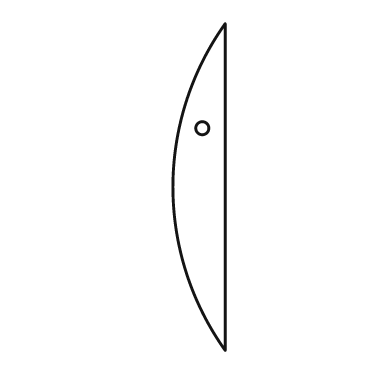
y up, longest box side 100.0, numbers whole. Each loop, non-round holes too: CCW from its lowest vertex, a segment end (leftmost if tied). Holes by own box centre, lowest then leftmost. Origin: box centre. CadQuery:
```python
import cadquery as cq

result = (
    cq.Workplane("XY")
    .moveTo(8.0, -50.0)
    .lineTo(8.0, 50.0)
    .threePointArc((-8.0, 0.0), (8.0, -50.0))
    .close()
    .moveTo(1.0, 18.0)
    .circle(2.0)
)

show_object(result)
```